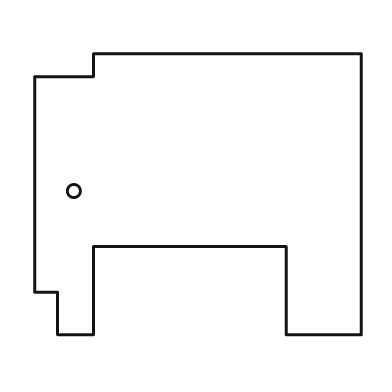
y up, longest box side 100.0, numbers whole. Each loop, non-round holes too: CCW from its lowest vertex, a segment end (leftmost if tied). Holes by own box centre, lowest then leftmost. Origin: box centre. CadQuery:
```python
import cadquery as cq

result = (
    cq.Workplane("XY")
    .moveTo(-43.0, -43.0)
    .lineTo(-32.0, -43.0)
    .lineTo(-32.0, -16.0)
    .lineTo(27.0, -16.0)
    .lineTo(27.0, -43.0)
    .lineTo(50.0, -43.0)
    .lineTo(50.0, 43.0)
    .lineTo(-32.0, 43.0)
    .lineTo(-32.0, 36.0)
    .lineTo(-50.0, 36.0)
    .lineTo(-50.0, -30.0)
    .lineTo(-43.0, -30.0)
    .close()
    .moveTo(-38.0, 1.0)
    .circle(2.0)
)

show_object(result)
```